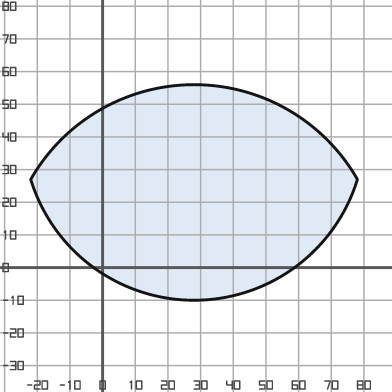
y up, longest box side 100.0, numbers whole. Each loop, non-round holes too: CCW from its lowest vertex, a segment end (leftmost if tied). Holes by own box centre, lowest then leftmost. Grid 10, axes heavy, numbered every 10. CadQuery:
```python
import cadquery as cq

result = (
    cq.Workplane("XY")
    .moveTo(-22.0, 27.0)
    .threePointArc((28.0, -10.0), (78.0, 27.0))
    .threePointArc((28.0, 56.0), (-22.0, 27.0))
    .close()
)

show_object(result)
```